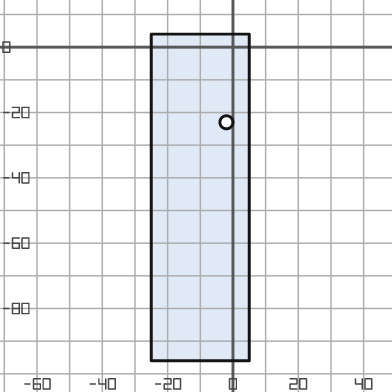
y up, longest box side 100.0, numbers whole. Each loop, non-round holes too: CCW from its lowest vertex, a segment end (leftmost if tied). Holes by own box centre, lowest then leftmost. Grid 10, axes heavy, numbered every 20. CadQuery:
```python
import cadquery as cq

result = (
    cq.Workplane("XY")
    .moveTo(-25.0, -96.0)
    .lineTo(5.0, -96.0)
    .lineTo(5.0, 4.0)
    .lineTo(-25.0, 4.0)
    .close()
    .moveTo(-2.0, -23.0)
    .circle(2.0)
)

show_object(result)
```